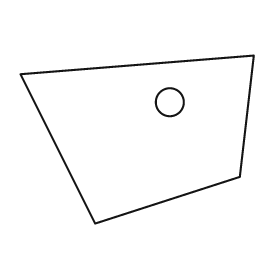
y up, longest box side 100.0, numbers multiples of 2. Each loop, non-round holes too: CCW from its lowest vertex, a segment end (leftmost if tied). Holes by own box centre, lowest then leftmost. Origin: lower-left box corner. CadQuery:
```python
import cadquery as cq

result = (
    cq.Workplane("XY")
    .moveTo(32.0, 0.0)
    .lineTo(94.0, 20.0)
    .lineTo(100.0, 72.0)
    .lineTo(0.0, 64.0)
    .close()
    .moveTo(64.0, 52.0)
    .circle(6.0)
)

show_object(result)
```